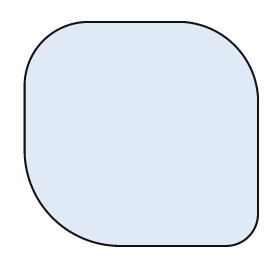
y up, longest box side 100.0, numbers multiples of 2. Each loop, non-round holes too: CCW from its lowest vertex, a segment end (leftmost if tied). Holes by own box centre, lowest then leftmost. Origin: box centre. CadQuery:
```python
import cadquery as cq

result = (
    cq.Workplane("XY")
    .moveTo(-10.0, -48.0)
    .lineTo(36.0, -48.0)
    .threePointArc((46.0, -44.0), (50.0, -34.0))
    .lineTo(50.0, 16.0)
    .threePointArc((40.0, 38.0), (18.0, 48.0))
    .lineTo(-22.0, 48.0)
    .threePointArc((-42.0, 40.0), (-50.0, 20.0))
    .lineTo(-50.0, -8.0)
    .threePointArc((-38.0, -36.0), (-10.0, -48.0))
    .close()
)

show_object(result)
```